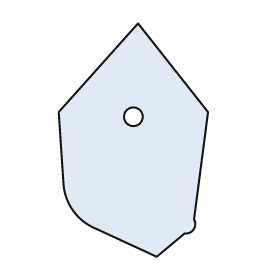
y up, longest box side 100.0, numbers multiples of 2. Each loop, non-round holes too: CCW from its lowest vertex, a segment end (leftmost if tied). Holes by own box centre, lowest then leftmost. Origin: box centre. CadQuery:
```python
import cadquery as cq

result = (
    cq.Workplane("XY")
    .moveTo(10.0, -50.0)
    .lineTo(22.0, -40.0)
    .threePointArc((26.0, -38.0), (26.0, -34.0))
    .lineTo(32.0, 12.0)
    .lineTo(2.0, 50.0)
    .lineTo(-32.0, 12.0)
    .lineTo(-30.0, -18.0)
    .threePointArc((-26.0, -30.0), (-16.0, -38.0))
    .close()
    .moveTo(0.0, 10.0)
    .circle(4.0)
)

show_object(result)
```